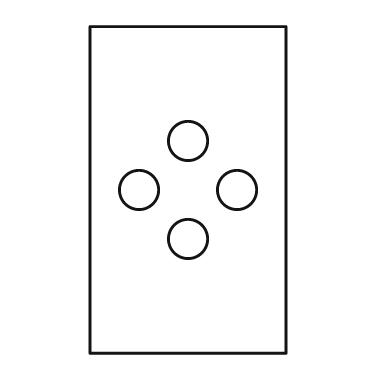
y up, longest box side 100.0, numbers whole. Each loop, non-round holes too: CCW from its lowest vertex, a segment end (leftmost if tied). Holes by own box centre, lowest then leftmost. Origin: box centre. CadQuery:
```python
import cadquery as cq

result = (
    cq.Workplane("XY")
    .moveTo(-30.0, -50.0)
    .lineTo(30.0, -50.0)
    .lineTo(30.0, 50.0)
    .lineTo(-30.0, 50.0)
    .close()
    .moveTo(0.0, -15.0)
    .circle(6.0)
    .moveTo(-15.0, 0.0)
    .circle(6.0)
    .moveTo(15.0, 0.0)
    .circle(6.0)
    .moveTo(0.0, 15.0)
    .circle(6.0)
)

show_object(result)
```